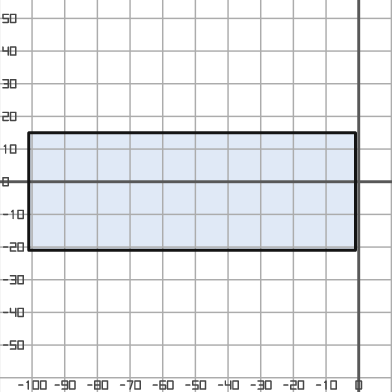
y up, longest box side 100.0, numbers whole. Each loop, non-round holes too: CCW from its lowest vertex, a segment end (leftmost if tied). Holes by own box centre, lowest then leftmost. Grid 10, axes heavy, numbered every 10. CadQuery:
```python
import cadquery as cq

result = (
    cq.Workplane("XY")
    .moveTo(-101.0, -21.0)
    .lineTo(-1.0, -21.0)
    .lineTo(-1.0, 15.0)
    .lineTo(-101.0, 15.0)
    .close()
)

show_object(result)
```